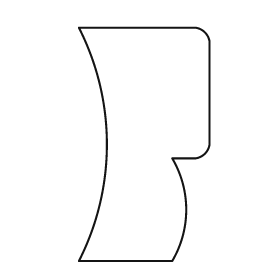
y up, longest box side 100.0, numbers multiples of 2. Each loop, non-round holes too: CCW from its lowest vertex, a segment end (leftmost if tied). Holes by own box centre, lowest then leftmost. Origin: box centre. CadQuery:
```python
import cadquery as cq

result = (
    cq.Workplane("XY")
    .moveTo(-28.0, -50.0)
    .lineTo(12.0, -50.0)
    .threePointArc((18.0, -28.0), (12.0, -6.0))
    .lineTo(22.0, -6.0)
    .threePointArc((26.0, -4.0), (28.0, 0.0))
    .lineTo(28.0, 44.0)
    .threePointArc((26.0, 48.0), (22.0, 50.0))
    .lineTo(-28.0, 50.0)
    .threePointArc((-16.0, 0.0), (-28.0, -50.0))
    .close()
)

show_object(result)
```